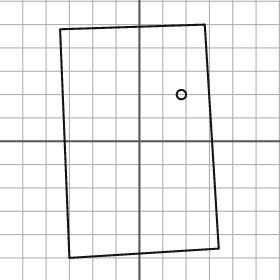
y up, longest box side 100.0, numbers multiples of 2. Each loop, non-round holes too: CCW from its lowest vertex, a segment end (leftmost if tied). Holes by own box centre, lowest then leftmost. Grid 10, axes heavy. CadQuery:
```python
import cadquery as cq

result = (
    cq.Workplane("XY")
    .moveTo(-30.0, -50.0)
    .lineTo(34.0, -46.0)
    .lineTo(28.0, 50.0)
    .lineTo(-34.0, 48.0)
    .close()
    .moveTo(18.0, 20.0)
    .circle(2.0)
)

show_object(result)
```